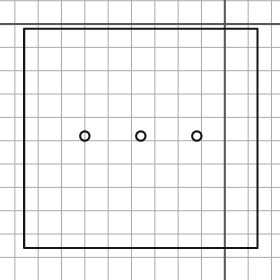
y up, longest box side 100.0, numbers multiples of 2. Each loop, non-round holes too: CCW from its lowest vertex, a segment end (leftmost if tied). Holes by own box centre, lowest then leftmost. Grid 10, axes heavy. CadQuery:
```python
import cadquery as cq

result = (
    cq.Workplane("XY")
    .moveTo(-86.0, -96.0)
    .lineTo(14.0, -96.0)
    .lineTo(14.0, -2.0)
    .lineTo(-86.0, -2.0)
    .close()
    .moveTo(-60.0, -48.0)
    .circle(2.0)
    .moveTo(-36.0, -48.0)
    .circle(2.0)
    .moveTo(-12.0, -48.0)
    .circle(2.0)
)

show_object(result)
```